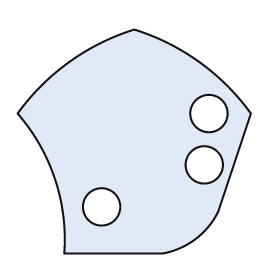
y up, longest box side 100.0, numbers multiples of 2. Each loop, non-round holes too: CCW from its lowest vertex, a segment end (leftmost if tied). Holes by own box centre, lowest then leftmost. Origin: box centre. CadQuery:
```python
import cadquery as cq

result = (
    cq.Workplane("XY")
    .moveTo(-30.0, -48.0)
    .lineTo(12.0, -48.0)
    .threePointArc((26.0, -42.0), (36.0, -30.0))
    .lineTo(50.0, 12.0)
    .threePointArc((28.0, 34.0), (0.0, 48.0))
    .threePointArc((-28.0, 34.0), (-50.0, 12.0))
    .threePointArc((-34.0, -16.0), (-30.0, -48.0))
    .close()
    .moveTo(-14.0, -28.0)
    .circle(8.0)
    .moveTo(30.0, -10.0)
    .circle(8.0)
    .moveTo(32.0, 12.0)
    .circle(8.0)
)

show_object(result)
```